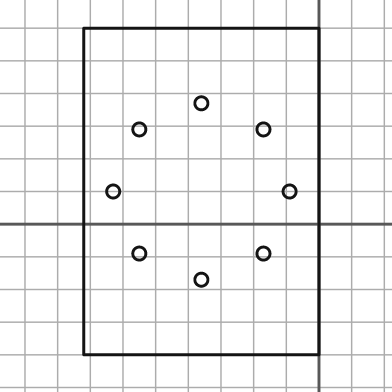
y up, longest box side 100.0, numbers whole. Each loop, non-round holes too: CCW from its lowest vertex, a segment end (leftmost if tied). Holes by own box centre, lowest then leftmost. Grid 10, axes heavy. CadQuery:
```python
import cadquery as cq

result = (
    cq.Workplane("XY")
    .moveTo(-72.0, -40.0)
    .lineTo(0.0, -40.0)
    .lineTo(0.0, 60.0)
    .lineTo(-72.0, 60.0)
    .close()
    .moveTo(-36.0, -17.0)
    .circle(2.0)
    .moveTo(-55.0, -9.0)
    .circle(2.0)
    .moveTo(-17.0, -9.0)
    .circle(2.0)
    .moveTo(-63.0, 10.0)
    .circle(2.0)
    .moveTo(-9.0, 10.0)
    .circle(2.0)
    .moveTo(-55.0, 29.0)
    .circle(2.0)
    .moveTo(-17.0, 29.0)
    .circle(2.0)
    .moveTo(-36.0, 37.0)
    .circle(2.0)
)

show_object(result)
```